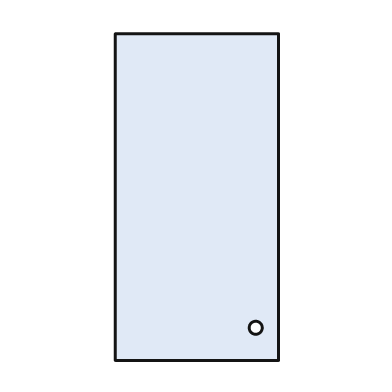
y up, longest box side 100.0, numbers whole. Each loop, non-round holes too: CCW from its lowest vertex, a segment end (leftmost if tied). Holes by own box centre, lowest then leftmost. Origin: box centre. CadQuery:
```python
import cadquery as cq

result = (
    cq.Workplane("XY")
    .moveTo(-25.0, -50.0)
    .lineTo(25.0, -50.0)
    .lineTo(25.0, 50.0)
    .lineTo(-25.0, 50.0)
    .close()
    .moveTo(18.0, -40.0)
    .circle(2.0)
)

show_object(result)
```